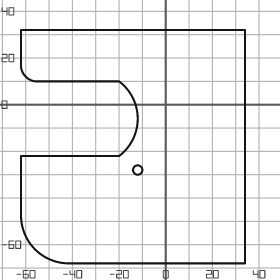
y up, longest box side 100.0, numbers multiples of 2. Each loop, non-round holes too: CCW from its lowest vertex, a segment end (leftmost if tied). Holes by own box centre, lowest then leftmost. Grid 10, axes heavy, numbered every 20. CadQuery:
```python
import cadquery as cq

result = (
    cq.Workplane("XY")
    .moveTo(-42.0, -68.0)
    .lineTo(34.0, -68.0)
    .lineTo(34.0, 32.0)
    .lineTo(-62.0, 32.0)
    .lineTo(-62.0, 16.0)
    .threePointArc((-60.0, 12.0), (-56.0, 10.0))
    .lineTo(-20.0, 10.0)
    .threePointArc((-12.0, -6.0), (-20.0, -22.0))
    .lineTo(-62.0, -22.0)
    .lineTo(-62.0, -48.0)
    .threePointArc((-56.0, -62.0), (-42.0, -68.0))
    .close()
    .moveTo(-12.0, -28.0)
    .circle(2.0)
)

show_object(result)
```